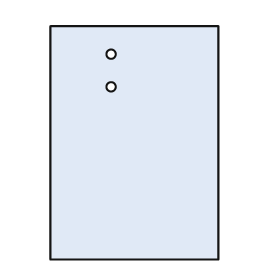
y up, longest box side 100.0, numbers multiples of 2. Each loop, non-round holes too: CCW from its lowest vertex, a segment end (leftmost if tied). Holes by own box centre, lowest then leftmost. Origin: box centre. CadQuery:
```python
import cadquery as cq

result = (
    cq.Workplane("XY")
    .moveTo(-36.0, -50.0)
    .lineTo(36.0, -50.0)
    .lineTo(36.0, 50.0)
    .lineTo(-36.0, 50.0)
    .close()
    .moveTo(-10.0, 24.0)
    .circle(2.0)
    .moveTo(-10.0, 38.0)
    .circle(2.0)
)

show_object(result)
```